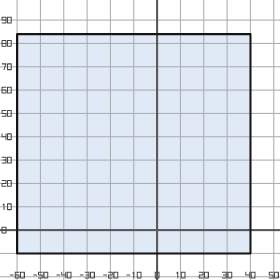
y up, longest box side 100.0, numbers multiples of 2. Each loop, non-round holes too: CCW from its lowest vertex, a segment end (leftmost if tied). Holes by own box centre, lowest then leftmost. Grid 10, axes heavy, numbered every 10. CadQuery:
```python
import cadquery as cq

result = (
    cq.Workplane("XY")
    .moveTo(-60.0, -10.0)
    .lineTo(40.0, -10.0)
    .lineTo(40.0, 84.0)
    .lineTo(-60.0, 84.0)
    .close()
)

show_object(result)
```